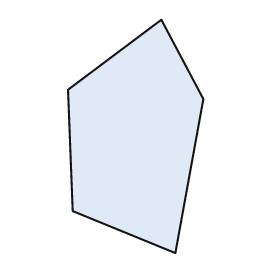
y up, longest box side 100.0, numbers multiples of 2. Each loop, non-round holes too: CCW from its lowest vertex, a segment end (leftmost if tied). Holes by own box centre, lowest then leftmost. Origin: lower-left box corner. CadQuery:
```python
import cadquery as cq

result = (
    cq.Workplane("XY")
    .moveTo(46.0, 0.0)
    .lineTo(58.0, 66.0)
    .lineTo(40.0, 100.0)
    .lineTo(0.0, 70.0)
    .lineTo(2.0, 18.0)
    .close()
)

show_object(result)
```